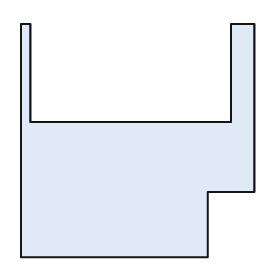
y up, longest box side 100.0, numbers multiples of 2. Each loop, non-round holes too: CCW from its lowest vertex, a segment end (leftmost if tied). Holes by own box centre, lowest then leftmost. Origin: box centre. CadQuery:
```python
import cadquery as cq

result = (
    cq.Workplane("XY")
    .moveTo(-50.0, -50.0)
    .lineTo(30.0, -50.0)
    .lineTo(30.0, -22.0)
    .lineTo(50.0, -22.0)
    .lineTo(50.0, 50.0)
    .lineTo(40.0, 50.0)
    .lineTo(40.0, 8.0)
    .lineTo(-46.0, 8.0)
    .lineTo(-46.0, 50.0)
    .lineTo(-50.0, 50.0)
    .close()
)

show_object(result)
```